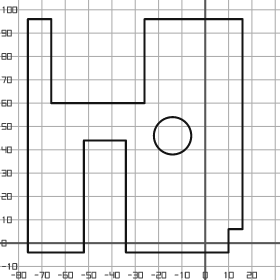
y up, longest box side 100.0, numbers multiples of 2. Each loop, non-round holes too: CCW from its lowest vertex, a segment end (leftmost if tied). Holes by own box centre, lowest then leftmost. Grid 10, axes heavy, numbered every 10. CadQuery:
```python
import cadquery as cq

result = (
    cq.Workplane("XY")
    .moveTo(-76.0, -4.0)
    .lineTo(-52.0, -4.0)
    .lineTo(-52.0, 44.0)
    .lineTo(-34.0, 44.0)
    .lineTo(-34.0, -4.0)
    .lineTo(10.0, -4.0)
    .lineTo(10.0, 6.0)
    .lineTo(16.0, 6.0)
    .lineTo(16.0, 96.0)
    .lineTo(-26.0, 96.0)
    .lineTo(-26.0, 60.0)
    .lineTo(-66.0, 60.0)
    .lineTo(-66.0, 96.0)
    .lineTo(-76.0, 96.0)
    .close()
    .moveTo(-14.0, 46.0)
    .circle(8.0)
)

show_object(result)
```